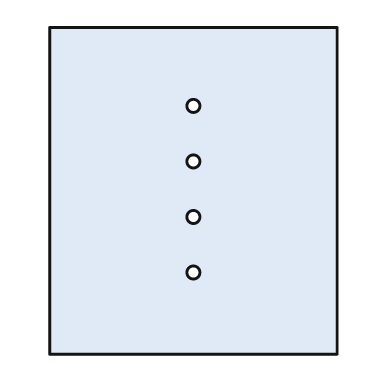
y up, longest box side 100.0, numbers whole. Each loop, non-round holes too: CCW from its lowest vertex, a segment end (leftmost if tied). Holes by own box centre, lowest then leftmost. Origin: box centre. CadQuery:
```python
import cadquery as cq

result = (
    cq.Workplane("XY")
    .moveTo(-44.0, -50.0)
    .lineTo(44.0, -50.0)
    .lineTo(44.0, 50.0)
    .lineTo(-44.0, 50.0)
    .close()
    .moveTo(0.0, -25.0)
    .circle(2.0)
    .moveTo(0.0, -8.0)
    .circle(2.0)
    .moveTo(0.0, 9.0)
    .circle(2.0)
    .moveTo(0.0, 26.0)
    .circle(2.0)
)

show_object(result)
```